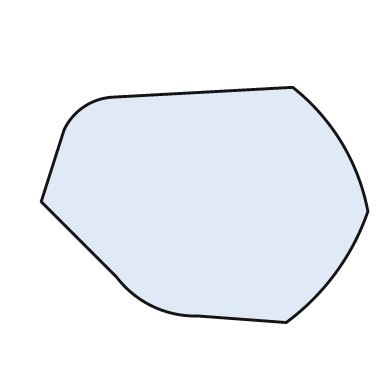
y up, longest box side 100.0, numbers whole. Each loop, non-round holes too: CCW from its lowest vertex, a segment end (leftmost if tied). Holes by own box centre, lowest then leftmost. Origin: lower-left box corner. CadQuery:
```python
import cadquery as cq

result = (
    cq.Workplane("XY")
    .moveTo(75.0, 0.0)
    .threePointArc((90.0, 15.0), (100.0, 34.0))
    .threePointArc((92.0, 55.0), (77.0, 72.0))
    .lineTo(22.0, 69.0)
    .threePointArc((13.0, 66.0), (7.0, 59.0))
    .lineTo(0.0, 37.0)
    .lineTo(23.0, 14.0)
    .threePointArc((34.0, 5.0), (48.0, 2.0))
    .close()
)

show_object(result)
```